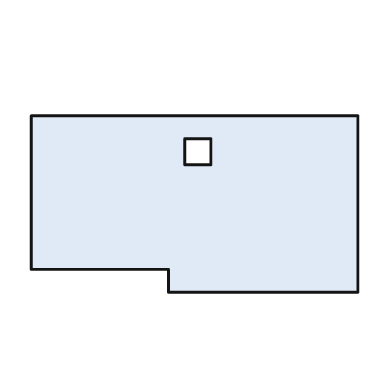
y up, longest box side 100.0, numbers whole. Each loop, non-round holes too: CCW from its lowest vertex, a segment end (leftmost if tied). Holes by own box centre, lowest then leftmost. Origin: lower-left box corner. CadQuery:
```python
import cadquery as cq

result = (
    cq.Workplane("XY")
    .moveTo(42.0, 0.0)
    .lineTo(100.0, 0.0)
    .lineTo(100.0, 54.0)
    .lineTo(0.0, 54.0)
    .lineTo(0.0, 7.0)
    .lineTo(42.0, 7.0)
    .close()
    .moveTo(47.0, 39.0)
    .lineTo(55.0, 39.0)
    .lineTo(55.0, 47.0)
    .lineTo(47.0, 47.0)
    .close()
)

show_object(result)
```